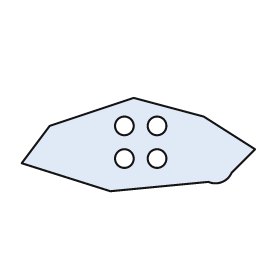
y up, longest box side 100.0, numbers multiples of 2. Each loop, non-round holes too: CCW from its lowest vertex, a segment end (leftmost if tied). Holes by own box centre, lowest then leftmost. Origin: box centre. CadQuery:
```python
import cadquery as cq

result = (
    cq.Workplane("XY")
    .moveTo(-12.0, -20.0)
    .lineTo(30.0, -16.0)
    .threePointArc((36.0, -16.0), (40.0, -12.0))
    .lineTo(50.0, -2.0)
    .lineTo(28.0, 12.0)
    .lineTo(-2.0, 20.0)
    .lineTo(-38.0, 8.0)
    .lineTo(-50.0, -8.0)
    .close()
    .moveTo(-6.0, -6.0)
    .circle(4.0)
    .moveTo(8.0, -6.0)
    .circle(4.0)
    .moveTo(-6.0, 8.0)
    .circle(4.0)
    .moveTo(8.0, 8.0)
    .circle(4.0)
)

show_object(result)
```